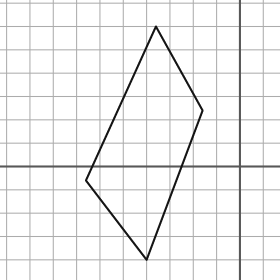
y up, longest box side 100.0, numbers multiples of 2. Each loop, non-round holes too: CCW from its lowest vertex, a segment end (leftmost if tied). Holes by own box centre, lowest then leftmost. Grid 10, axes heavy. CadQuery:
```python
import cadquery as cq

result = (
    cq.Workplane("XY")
    .moveTo(-40.0, -40.0)
    .lineTo(-16.0, 24.0)
    .lineTo(-36.0, 60.0)
    .lineTo(-66.0, -6.0)
    .close()
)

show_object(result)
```